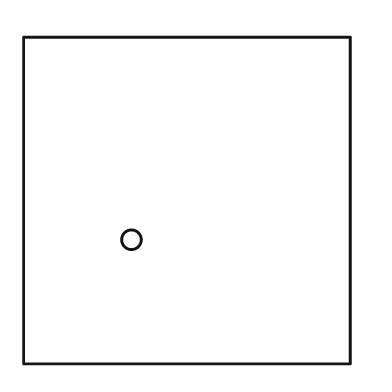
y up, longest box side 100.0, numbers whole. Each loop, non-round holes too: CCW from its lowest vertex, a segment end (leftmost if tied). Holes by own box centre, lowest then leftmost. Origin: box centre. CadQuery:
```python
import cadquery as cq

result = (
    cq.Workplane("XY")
    .moveTo(-50.0, -50.0)
    .lineTo(50.0, -50.0)
    .lineTo(50.0, 50.0)
    .lineTo(-50.0, 50.0)
    .close()
    .moveTo(-17.0, -12.0)
    .circle(3.0)
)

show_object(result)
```